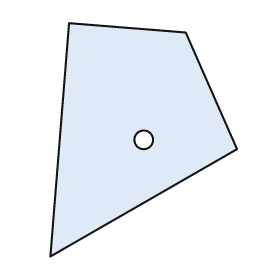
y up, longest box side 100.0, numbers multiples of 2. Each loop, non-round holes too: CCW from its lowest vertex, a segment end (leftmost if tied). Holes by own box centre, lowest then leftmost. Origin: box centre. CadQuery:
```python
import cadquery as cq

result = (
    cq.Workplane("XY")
    .moveTo(-40.0, -50.0)
    .lineTo(40.0, -4.0)
    .lineTo(18.0, 46.0)
    .lineTo(-32.0, 50.0)
    .close()
    .moveTo(0.0, 0.0)
    .circle(4.0)
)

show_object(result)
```